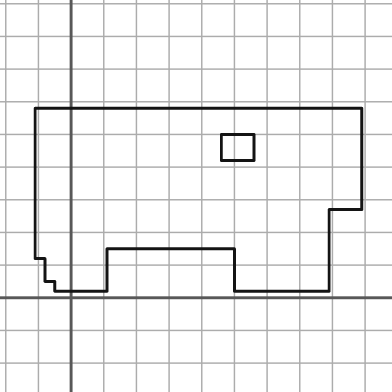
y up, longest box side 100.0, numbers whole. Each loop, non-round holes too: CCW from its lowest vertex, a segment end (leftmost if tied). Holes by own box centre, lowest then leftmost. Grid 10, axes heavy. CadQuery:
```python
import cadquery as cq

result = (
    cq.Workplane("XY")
    .moveTo(-5.0, 2.0)
    .lineTo(11.0, 2.0)
    .lineTo(11.0, 15.0)
    .lineTo(50.0, 15.0)
    .lineTo(50.0, 2.0)
    .lineTo(79.0, 2.0)
    .lineTo(79.0, 27.0)
    .lineTo(89.0, 27.0)
    .lineTo(89.0, 58.0)
    .lineTo(-11.0, 58.0)
    .lineTo(-11.0, 12.0)
    .lineTo(-8.0, 12.0)
    .lineTo(-8.0, 5.0)
    .lineTo(-5.0, 5.0)
    .close()
    .moveTo(46.0, 42.0)
    .lineTo(56.0, 42.0)
    .lineTo(56.0, 50.0)
    .lineTo(46.0, 50.0)
    .close()
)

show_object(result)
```